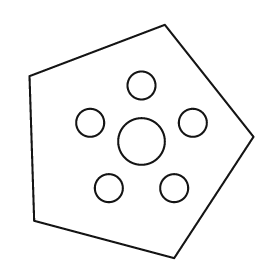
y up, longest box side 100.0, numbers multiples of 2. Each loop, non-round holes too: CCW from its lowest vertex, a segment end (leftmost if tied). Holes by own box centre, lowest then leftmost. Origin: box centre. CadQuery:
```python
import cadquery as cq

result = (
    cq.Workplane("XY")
    .moveTo(14.0, -50.0)
    .lineTo(48.0, 2.0)
    .lineTo(10.0, 50.0)
    .lineTo(-48.0, 28.0)
    .lineTo(-46.0, -34.0)
    .close()
    .moveTo(-14.0, -20.0)
    .circle(6.0)
    .moveTo(14.0, -20.0)
    .circle(6.0)
    .moveTo(0.0, 0.0)
    .circle(10.0)
    .moveTo(-22.0, 8.0)
    .circle(6.0)
    .moveTo(22.0, 8.0)
    .circle(6.0)
    .moveTo(0.0, 24.0)
    .circle(6.0)
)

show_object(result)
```